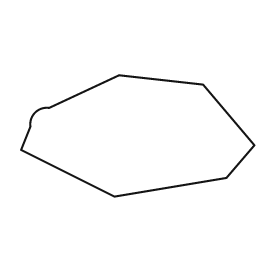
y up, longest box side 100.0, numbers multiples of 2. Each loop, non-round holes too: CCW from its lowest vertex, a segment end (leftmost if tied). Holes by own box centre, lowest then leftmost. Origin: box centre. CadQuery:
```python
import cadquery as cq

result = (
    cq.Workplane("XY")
    .moveTo(-10.0, -26.0)
    .lineTo(38.0, -18.0)
    .lineTo(50.0, -4.0)
    .lineTo(28.0, 22.0)
    .lineTo(-8.0, 26.0)
    .lineTo(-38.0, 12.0)
    .threePointArc((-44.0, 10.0), (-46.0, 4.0))
    .lineTo(-50.0, -6.0)
    .close()
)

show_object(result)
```